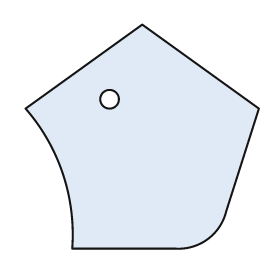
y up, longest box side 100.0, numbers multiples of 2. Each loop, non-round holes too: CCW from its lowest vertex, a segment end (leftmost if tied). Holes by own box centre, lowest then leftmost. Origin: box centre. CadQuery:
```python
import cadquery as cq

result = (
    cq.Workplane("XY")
    .moveTo(-30.0, -48.0)
    .lineTo(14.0, -48.0)
    .threePointArc((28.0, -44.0), (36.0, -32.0))
    .lineTo(50.0, 12.0)
    .lineTo(0.0, 48.0)
    .lineTo(-50.0, 12.0)
    .threePointArc((-34.0, -16.0), (-30.0, -48.0))
    .close()
    .moveTo(-14.0, 16.0)
    .circle(4.0)
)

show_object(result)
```